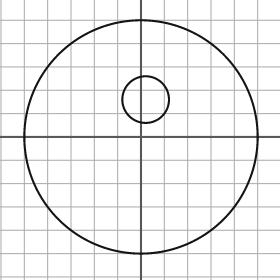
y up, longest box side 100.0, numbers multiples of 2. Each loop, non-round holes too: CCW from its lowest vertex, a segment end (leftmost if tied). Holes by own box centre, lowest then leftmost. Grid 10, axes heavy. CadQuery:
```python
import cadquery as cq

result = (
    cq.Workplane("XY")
    .moveTo(0.0, 0.0)
    .circle(50.0)
    .moveTo(2.0, 16.0)
    .circle(10.0)
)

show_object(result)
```